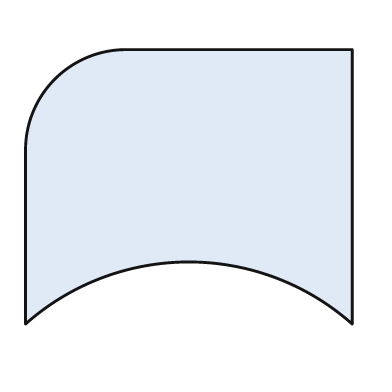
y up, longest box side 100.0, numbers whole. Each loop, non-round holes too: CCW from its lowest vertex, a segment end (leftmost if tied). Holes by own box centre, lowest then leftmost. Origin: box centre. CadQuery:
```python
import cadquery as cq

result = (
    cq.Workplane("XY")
    .moveTo(-50.0, -42.0)
    .threePointArc((0.0, -23.0), (50.0, -42.0))
    .lineTo(50.0, 42.0)
    .lineTo(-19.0, 42.0)
    .threePointArc((-41.0, 33.0), (-50.0, 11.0))
    .close()
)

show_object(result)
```